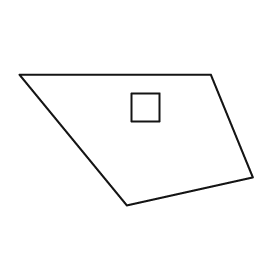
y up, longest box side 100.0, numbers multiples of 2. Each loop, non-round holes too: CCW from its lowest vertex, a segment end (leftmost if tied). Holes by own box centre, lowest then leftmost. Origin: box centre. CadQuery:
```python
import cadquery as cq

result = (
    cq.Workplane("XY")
    .moveTo(-4.0, -28.0)
    .lineTo(50.0, -16.0)
    .lineTo(32.0, 28.0)
    .lineTo(-50.0, 28.0)
    .close()
    .moveTo(-2.0, 8.0)
    .lineTo(10.0, 8.0)
    .lineTo(10.0, 20.0)
    .lineTo(-2.0, 20.0)
    .close()
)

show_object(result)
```